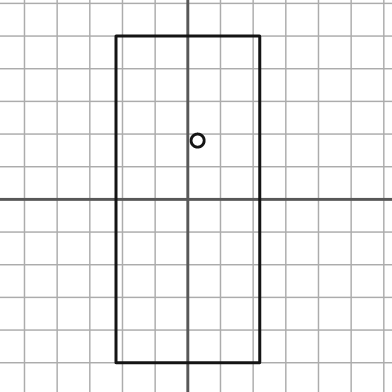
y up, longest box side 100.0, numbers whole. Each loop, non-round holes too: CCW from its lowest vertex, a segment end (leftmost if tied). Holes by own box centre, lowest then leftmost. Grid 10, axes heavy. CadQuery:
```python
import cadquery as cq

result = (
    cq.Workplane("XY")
    .moveTo(-22.0, -50.0)
    .lineTo(22.0, -50.0)
    .lineTo(22.0, 50.0)
    .lineTo(-22.0, 50.0)
    .close()
    .moveTo(3.0, 18.0)
    .circle(2.0)
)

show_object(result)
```